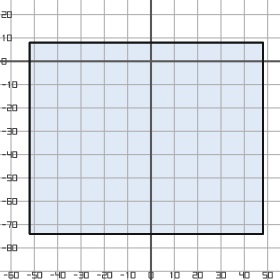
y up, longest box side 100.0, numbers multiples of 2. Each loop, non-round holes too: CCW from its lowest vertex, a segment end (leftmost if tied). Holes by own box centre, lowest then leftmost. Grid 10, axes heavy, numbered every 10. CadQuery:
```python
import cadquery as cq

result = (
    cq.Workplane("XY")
    .moveTo(-52.0, -74.0)
    .lineTo(48.0, -74.0)
    .lineTo(48.0, 8.0)
    .lineTo(-52.0, 8.0)
    .close()
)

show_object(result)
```